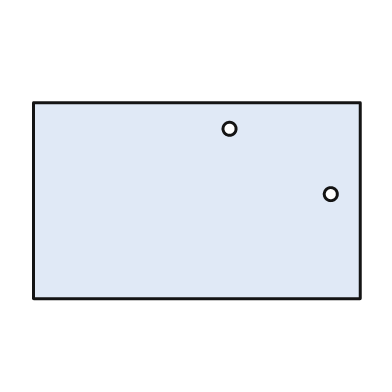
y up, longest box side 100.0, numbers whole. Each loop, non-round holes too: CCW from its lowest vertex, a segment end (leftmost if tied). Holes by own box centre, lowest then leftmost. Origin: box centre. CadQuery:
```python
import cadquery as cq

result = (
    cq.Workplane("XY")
    .moveTo(-50.0, -30.0)
    .lineTo(50.0, -30.0)
    .lineTo(50.0, 30.0)
    .lineTo(-50.0, 30.0)
    .close()
    .moveTo(41.0, 2.0)
    .circle(2.0)
    .moveTo(10.0, 22.0)
    .circle(2.0)
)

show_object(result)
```